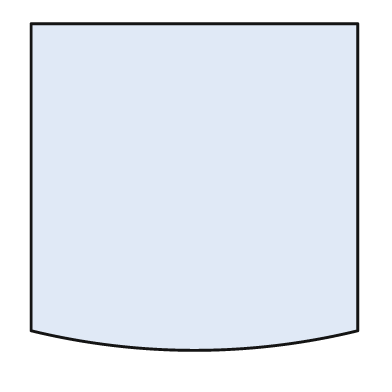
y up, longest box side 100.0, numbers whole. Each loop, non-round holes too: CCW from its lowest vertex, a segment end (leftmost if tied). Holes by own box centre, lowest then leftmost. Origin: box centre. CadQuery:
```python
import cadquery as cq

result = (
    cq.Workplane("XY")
    .moveTo(-50.0, -44.0)
    .threePointArc((0.0, -50.0), (50.0, -44.0))
    .lineTo(50.0, 50.0)
    .lineTo(-50.0, 50.0)
    .close()
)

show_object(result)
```